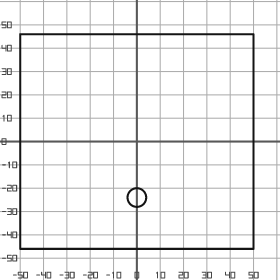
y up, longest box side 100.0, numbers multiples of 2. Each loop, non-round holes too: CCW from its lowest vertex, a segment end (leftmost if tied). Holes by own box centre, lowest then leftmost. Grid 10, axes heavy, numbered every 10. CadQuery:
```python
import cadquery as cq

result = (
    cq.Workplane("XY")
    .moveTo(-50.0, -46.0)
    .lineTo(50.0, -46.0)
    .lineTo(50.0, 46.0)
    .lineTo(-50.0, 46.0)
    .close()
    .moveTo(0.0, -24.0)
    .circle(4.0)
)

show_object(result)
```